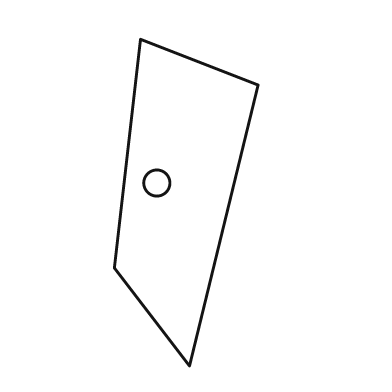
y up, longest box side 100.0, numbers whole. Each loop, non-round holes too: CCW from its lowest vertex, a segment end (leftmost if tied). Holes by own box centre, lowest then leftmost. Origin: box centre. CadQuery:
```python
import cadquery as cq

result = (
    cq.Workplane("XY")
    .moveTo(1.0, -50.0)
    .lineTo(22.0, 36.0)
    .lineTo(-14.0, 50.0)
    .lineTo(-22.0, -20.0)
    .close()
    .moveTo(-9.0, 6.0)
    .circle(4.0)
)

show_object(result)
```